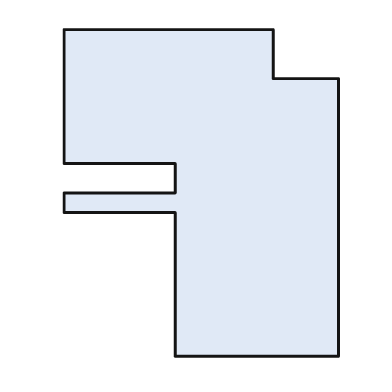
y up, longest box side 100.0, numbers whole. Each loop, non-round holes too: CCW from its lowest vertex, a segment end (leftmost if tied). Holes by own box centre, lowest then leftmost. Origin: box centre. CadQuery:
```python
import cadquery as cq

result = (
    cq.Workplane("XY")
    .moveTo(-8.0, -50.0)
    .lineTo(42.0, -50.0)
    .lineTo(42.0, 35.0)
    .lineTo(22.0, 35.0)
    .lineTo(22.0, 50.0)
    .lineTo(-42.0, 50.0)
    .lineTo(-42.0, 9.0)
    .lineTo(-8.0, 9.0)
    .lineTo(-8.0, 0.0)
    .lineTo(-42.0, 0.0)
    .lineTo(-42.0, -6.0)
    .lineTo(-8.0, -6.0)
    .close()
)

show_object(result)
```